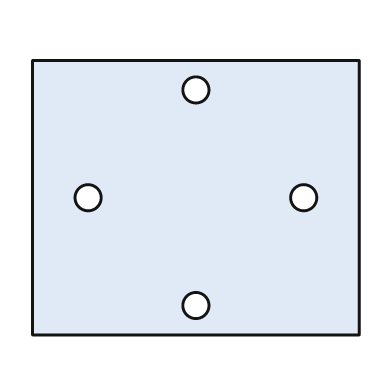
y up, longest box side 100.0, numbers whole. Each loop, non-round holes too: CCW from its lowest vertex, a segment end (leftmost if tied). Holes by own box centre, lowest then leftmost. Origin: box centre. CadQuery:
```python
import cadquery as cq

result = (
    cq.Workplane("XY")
    .moveTo(-50.0, -42.0)
    .lineTo(50.0, -42.0)
    .lineTo(50.0, 42.0)
    .lineTo(-50.0, 42.0)
    .close()
    .moveTo(0.0, -33.0)
    .circle(4.0)
    .moveTo(-33.0, 0.0)
    .circle(4.0)
    .moveTo(33.0, 0.0)
    .circle(4.0)
    .moveTo(0.0, 33.0)
    .circle(4.0)
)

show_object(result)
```